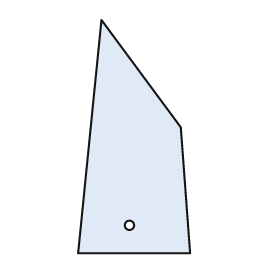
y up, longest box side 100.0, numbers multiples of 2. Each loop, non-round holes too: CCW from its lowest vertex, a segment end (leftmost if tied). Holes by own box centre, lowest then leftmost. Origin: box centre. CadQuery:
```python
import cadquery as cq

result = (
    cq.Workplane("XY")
    .moveTo(-24.0, -50.0)
    .lineTo(24.0, -50.0)
    .lineTo(20.0, 4.0)
    .lineTo(-14.0, 50.0)
    .close()
    .moveTo(-2.0, -38.0)
    .circle(2.0)
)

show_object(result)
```